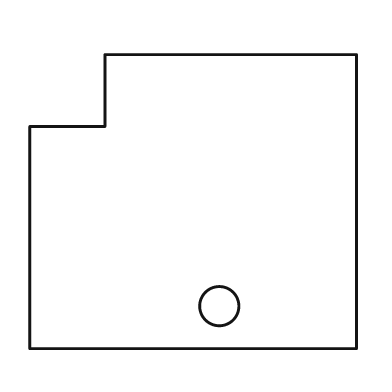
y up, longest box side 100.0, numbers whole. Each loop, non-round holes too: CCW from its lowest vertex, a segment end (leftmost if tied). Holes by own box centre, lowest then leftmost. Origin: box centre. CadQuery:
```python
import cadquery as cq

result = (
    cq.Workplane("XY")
    .moveTo(-50.0, -45.0)
    .lineTo(50.0, -45.0)
    .lineTo(50.0, 45.0)
    .lineTo(-27.0, 45.0)
    .lineTo(-27.0, 23.0)
    .lineTo(-50.0, 23.0)
    .close()
    .moveTo(8.0, -32.0)
    .circle(6.0)
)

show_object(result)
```